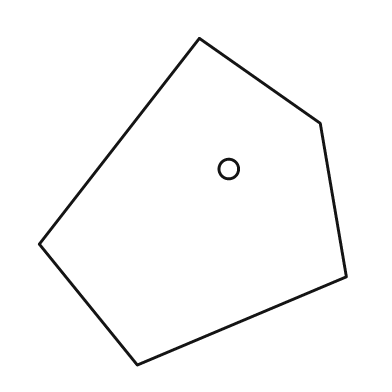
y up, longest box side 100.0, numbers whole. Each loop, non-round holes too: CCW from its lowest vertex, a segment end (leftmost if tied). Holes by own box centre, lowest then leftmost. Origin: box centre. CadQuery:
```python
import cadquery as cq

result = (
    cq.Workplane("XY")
    .moveTo(-17.0, -50.0)
    .lineTo(47.0, -23.0)
    .lineTo(39.0, 24.0)
    .lineTo(2.0, 50.0)
    .lineTo(-47.0, -13.0)
    .close()
    .moveTo(11.0, 10.0)
    .circle(3.0)
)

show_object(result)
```